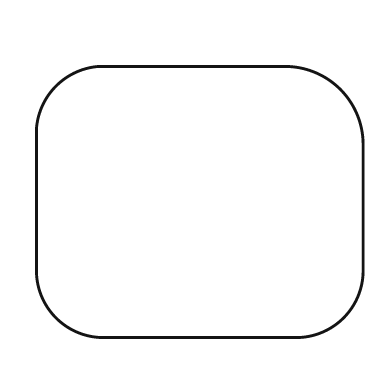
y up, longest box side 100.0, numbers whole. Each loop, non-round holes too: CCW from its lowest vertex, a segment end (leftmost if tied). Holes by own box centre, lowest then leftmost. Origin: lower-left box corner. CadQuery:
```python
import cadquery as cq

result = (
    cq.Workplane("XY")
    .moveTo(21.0, 0.0)
    .lineTo(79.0, 0.0)
    .threePointArc((94.0, 6.0), (100.0, 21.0))
    .lineTo(100.0, 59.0)
    .threePointArc((93.0, 76.0), (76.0, 83.0))
    .lineTo(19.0, 83.0)
    .threePointArc((6.0, 77.0), (0.0, 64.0))
    .lineTo(0.0, 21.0)
    .threePointArc((6.0, 6.0), (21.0, 0.0))
    .close()
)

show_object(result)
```